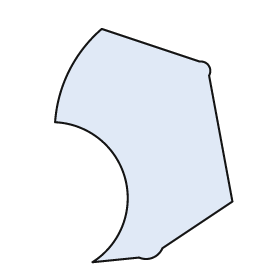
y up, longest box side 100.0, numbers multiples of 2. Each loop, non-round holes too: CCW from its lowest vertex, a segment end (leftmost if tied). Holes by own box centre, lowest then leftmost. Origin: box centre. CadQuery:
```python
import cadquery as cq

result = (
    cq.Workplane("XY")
    .moveTo(-22.0, -50.0)
    .lineTo(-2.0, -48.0)
    .threePointArc((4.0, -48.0), (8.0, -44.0))
    .lineTo(38.0, -24.0)
    .lineTo(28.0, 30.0)
    .threePointArc((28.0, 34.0), (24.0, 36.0))
    .lineTo(-18.0, 50.0)
    .threePointArc((-32.0, 32.0), (-38.0, 10.0))
    .threePointArc((-8.0, -14.0), (-22.0, -50.0))
    .close()
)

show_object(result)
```